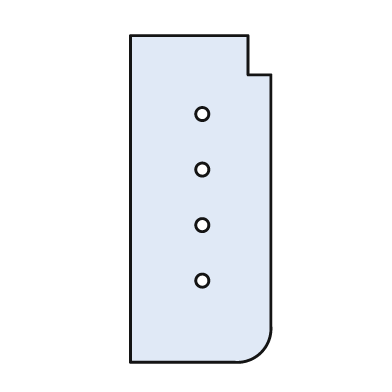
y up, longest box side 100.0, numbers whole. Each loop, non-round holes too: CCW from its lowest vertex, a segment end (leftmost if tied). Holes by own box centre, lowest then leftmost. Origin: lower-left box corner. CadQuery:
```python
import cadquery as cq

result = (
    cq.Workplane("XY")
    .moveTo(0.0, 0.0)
    .lineTo(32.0, 0.0)
    .threePointArc((40.0, 3.0), (43.0, 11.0))
    .lineTo(43.0, 88.0)
    .lineTo(36.0, 88.0)
    .lineTo(36.0, 100.0)
    .lineTo(0.0, 100.0)
    .close()
    .moveTo(22.0, 25.0)
    .circle(2.0)
    .moveTo(22.0, 42.0)
    .circle(2.0)
    .moveTo(22.0, 59.0)
    .circle(2.0)
    .moveTo(22.0, 76.0)
    .circle(2.0)
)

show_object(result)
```